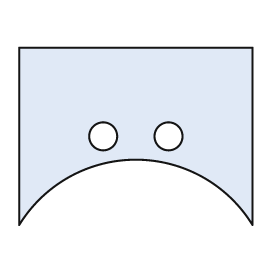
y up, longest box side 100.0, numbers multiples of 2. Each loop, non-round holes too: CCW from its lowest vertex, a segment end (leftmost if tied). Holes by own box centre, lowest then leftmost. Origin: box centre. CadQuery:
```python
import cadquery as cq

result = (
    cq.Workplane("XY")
    .moveTo(-50.0, -38.0)
    .threePointArc((0.0, -10.0), (50.0, -38.0))
    .lineTo(50.0, 38.0)
    .lineTo(-50.0, 38.0)
    .close()
    .moveTo(-14.0, 0.0)
    .circle(6.0)
    .moveTo(14.0, 0.0)
    .circle(6.0)
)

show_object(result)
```